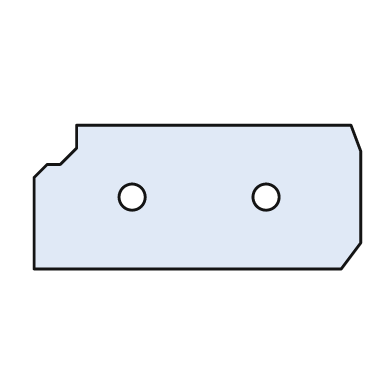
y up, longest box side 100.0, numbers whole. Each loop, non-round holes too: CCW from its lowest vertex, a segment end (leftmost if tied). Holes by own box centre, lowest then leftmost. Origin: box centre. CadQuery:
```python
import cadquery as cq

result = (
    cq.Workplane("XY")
    .moveTo(-50.0, -22.0)
    .lineTo(44.0, -22.0)
    .lineTo(50.0, -14.0)
    .lineTo(50.0, 14.0)
    .lineTo(47.0, 22.0)
    .lineTo(-37.0, 22.0)
    .lineTo(-37.0, 15.0)
    .lineTo(-42.0, 10.0)
    .lineTo(-46.0, 10.0)
    .lineTo(-50.0, 6.0)
    .close()
    .moveTo(-20.0, 0.0)
    .circle(4.0)
    .moveTo(21.0, 0.0)
    .circle(4.0)
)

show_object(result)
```